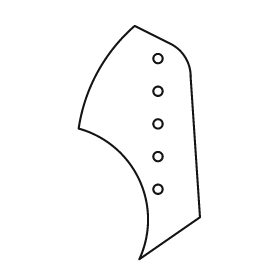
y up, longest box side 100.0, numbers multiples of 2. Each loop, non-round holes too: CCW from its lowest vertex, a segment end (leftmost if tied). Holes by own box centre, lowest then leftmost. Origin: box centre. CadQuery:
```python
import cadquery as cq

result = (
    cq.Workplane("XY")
    .moveTo(0.0, -50.0)
    .lineTo(26.0, -32.0)
    .lineTo(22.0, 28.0)
    .threePointArc((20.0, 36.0), (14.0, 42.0))
    .lineTo(-2.0, 50.0)
    .threePointArc((-18.0, 30.0), (-26.0, 6.0))
    .threePointArc((0.0, -16.0), (0.0, -50.0))
    .close()
    .moveTo(8.0, -20.0)
    .circle(2.0)
    .moveTo(8.0, -6.0)
    .circle(2.0)
    .moveTo(8.0, 8.0)
    .circle(2.0)
    .moveTo(8.0, 22.0)
    .circle(2.0)
    .moveTo(8.0, 36.0)
    .circle(2.0)
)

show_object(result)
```